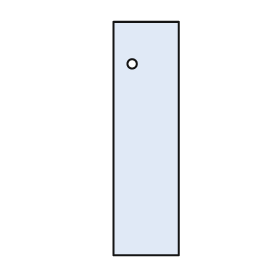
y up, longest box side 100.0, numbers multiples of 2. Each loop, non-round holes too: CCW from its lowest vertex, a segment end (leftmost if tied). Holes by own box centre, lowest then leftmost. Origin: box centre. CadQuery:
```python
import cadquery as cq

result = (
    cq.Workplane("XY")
    .moveTo(-14.0, -50.0)
    .lineTo(14.0, -50.0)
    .lineTo(14.0, 50.0)
    .lineTo(-14.0, 50.0)
    .close()
    .moveTo(-6.0, 32.0)
    .circle(2.0)
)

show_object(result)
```